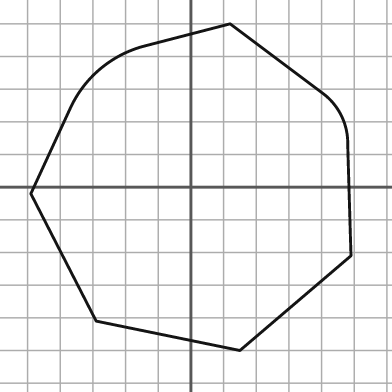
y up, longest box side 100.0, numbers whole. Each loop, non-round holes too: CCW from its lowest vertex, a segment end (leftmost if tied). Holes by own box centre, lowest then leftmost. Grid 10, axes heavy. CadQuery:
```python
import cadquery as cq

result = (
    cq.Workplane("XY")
    .moveTo(15.0, -50.0)
    .lineTo(49.0, -21.0)
    .lineTo(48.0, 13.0)
    .threePointArc((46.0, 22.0), (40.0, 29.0))
    .lineTo(12.0, 50.0)
    .lineTo(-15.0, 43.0)
    .threePointArc((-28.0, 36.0), (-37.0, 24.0))
    .lineTo(-49.0, -2.0)
    .lineTo(-29.0, -41.0)
    .close()
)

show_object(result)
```